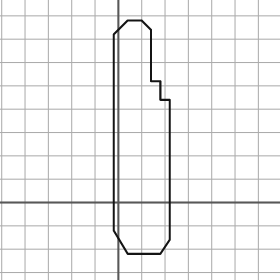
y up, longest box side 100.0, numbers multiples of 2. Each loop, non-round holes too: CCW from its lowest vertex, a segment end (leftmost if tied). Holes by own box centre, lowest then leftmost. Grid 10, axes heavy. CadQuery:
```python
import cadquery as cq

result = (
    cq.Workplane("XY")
    .moveTo(4.0, -22.0)
    .lineTo(18.0, -22.0)
    .lineTo(22.0, -16.0)
    .lineTo(22.0, 44.0)
    .lineTo(18.0, 44.0)
    .lineTo(18.0, 52.0)
    .lineTo(14.0, 52.0)
    .lineTo(14.0, 74.0)
    .lineTo(10.0, 78.0)
    .lineTo(4.0, 78.0)
    .lineTo(-2.0, 72.0)
    .lineTo(-2.0, -12.0)
    .close()
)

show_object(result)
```